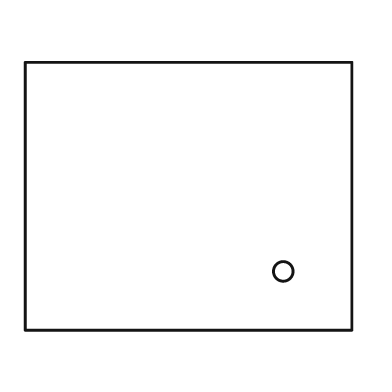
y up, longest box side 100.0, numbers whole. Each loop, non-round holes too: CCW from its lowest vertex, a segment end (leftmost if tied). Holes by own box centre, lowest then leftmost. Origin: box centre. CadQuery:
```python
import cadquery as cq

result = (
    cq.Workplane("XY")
    .moveTo(-50.0, -41.0)
    .lineTo(50.0, -41.0)
    .lineTo(50.0, 41.0)
    .lineTo(-50.0, 41.0)
    .close()
    .moveTo(29.0, -23.0)
    .circle(3.0)
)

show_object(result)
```